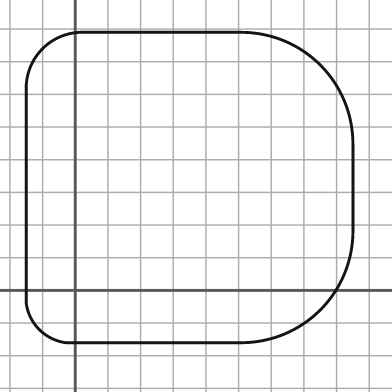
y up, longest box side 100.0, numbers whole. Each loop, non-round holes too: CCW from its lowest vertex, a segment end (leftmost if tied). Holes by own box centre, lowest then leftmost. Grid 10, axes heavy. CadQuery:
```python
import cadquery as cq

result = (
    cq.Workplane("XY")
    .moveTo(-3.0, -16.0)
    .lineTo(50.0, -16.0)
    .threePointArc((75.0, -6.0), (85.0, 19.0))
    .lineTo(85.0, 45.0)
    .threePointArc((75.0, 69.0), (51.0, 79.0))
    .lineTo(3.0, 79.0)
    .threePointArc((-10.0, 74.0), (-15.0, 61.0))
    .lineTo(-15.0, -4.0)
    .threePointArc((-11.0, -12.0), (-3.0, -16.0))
    .close()
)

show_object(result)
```